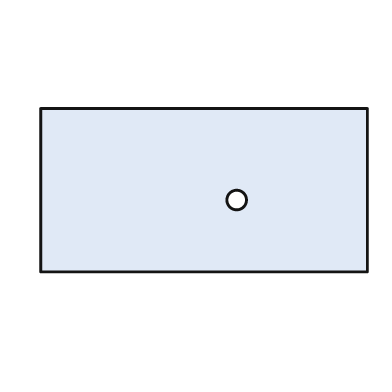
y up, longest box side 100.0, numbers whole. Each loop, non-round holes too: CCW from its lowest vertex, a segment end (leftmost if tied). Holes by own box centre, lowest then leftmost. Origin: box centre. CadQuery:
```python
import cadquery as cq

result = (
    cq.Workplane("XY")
    .moveTo(-50.0, -25.0)
    .lineTo(50.0, -25.0)
    .lineTo(50.0, 25.0)
    .lineTo(-50.0, 25.0)
    .close()
    .moveTo(10.0, -3.0)
    .circle(3.0)
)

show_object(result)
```